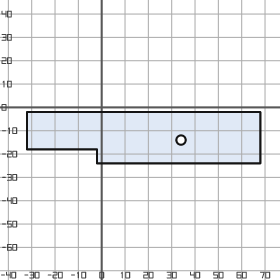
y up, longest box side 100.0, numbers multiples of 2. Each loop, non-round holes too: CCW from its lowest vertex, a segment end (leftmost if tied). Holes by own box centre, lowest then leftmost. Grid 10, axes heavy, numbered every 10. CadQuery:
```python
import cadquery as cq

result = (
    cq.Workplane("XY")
    .moveTo(-2.0, -24.0)
    .lineTo(68.0, -24.0)
    .lineTo(68.0, -2.0)
    .lineTo(-32.0, -2.0)
    .lineTo(-32.0, -18.0)
    .lineTo(-2.0, -18.0)
    .close()
    .moveTo(34.0, -14.0)
    .circle(2.0)
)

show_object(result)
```